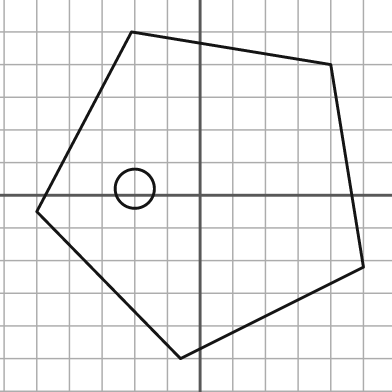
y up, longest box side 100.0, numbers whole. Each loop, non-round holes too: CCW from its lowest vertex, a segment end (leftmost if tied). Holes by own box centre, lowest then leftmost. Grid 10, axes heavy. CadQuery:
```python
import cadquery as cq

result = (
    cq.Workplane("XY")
    .moveTo(-6.0, -50.0)
    .lineTo(50.0, -22.0)
    .lineTo(40.0, 40.0)
    .lineTo(-21.0, 50.0)
    .lineTo(-50.0, -5.0)
    .close()
    .moveTo(-20.0, 2.0)
    .circle(6.0)
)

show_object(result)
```